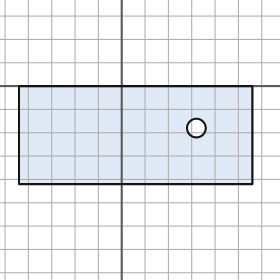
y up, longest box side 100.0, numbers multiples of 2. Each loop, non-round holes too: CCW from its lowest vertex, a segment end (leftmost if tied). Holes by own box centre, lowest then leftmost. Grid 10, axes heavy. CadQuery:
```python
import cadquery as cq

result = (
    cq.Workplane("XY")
    .moveTo(-44.0, -42.0)
    .lineTo(56.0, -42.0)
    .lineTo(56.0, 0.0)
    .lineTo(-44.0, 0.0)
    .close()
    .moveTo(32.0, -18.0)
    .circle(4.0)
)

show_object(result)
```